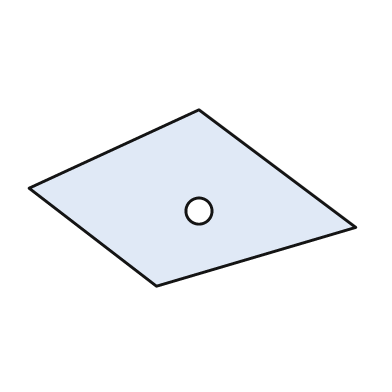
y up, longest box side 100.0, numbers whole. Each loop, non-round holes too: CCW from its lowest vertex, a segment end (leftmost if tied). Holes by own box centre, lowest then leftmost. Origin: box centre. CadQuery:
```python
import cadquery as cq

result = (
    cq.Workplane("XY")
    .moveTo(-11.0, -27.0)
    .lineTo(50.0, -9.0)
    .lineTo(2.0, 27.0)
    .lineTo(-50.0, 3.0)
    .close()
    .moveTo(2.0, -4.0)
    .circle(4.0)
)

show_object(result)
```